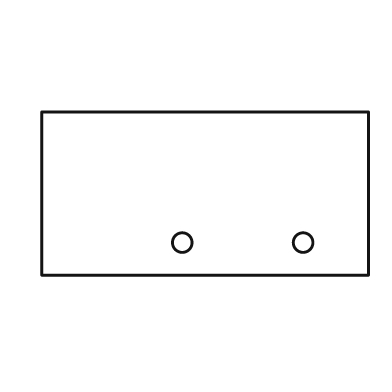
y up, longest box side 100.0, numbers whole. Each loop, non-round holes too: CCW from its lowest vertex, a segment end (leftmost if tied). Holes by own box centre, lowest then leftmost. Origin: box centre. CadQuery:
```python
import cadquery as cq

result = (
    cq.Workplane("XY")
    .moveTo(-50.0, -25.0)
    .lineTo(50.0, -25.0)
    .lineTo(50.0, 25.0)
    .lineTo(-50.0, 25.0)
    .close()
    .moveTo(-7.0, -15.0)
    .circle(3.0)
    .moveTo(30.0, -15.0)
    .circle(3.0)
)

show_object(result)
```